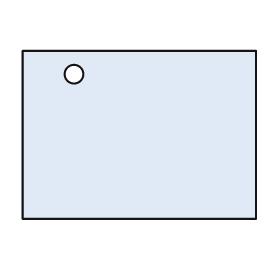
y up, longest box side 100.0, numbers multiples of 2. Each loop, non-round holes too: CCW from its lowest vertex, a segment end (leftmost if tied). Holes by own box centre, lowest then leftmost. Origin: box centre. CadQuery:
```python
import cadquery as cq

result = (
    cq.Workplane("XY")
    .moveTo(-50.0, -36.0)
    .lineTo(50.0, -36.0)
    .lineTo(50.0, 36.0)
    .lineTo(-50.0, 36.0)
    .close()
    .moveTo(-28.0, 26.0)
    .circle(4.0)
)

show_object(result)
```